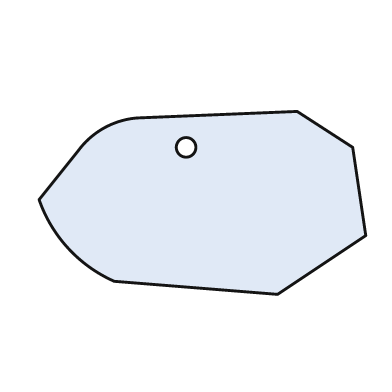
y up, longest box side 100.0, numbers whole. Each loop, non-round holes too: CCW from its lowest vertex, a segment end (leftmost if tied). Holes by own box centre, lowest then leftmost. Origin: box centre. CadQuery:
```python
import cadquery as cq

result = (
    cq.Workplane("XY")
    .moveTo(23.0, -28.0)
    .lineTo(50.0, -10.0)
    .lineTo(46.0, 17.0)
    .lineTo(29.0, 28.0)
    .lineTo(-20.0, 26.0)
    .threePointArc((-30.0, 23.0), (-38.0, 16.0))
    .lineTo(-50.0, 1.0)
    .threePointArc((-41.0, -14.0), (-27.0, -24.0))
    .close()
    .moveTo(-5.0, 17.0)
    .circle(3.0)
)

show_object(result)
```